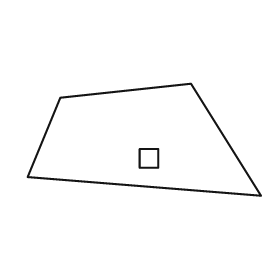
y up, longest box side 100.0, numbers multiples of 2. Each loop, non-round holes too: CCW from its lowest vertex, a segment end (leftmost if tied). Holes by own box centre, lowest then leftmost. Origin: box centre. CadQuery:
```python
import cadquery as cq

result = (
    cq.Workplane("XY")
    .moveTo(50.0, -24.0)
    .lineTo(20.0, 24.0)
    .lineTo(-36.0, 18.0)
    .lineTo(-50.0, -16.0)
    .close()
    .moveTo(-2.0, -12.0)
    .lineTo(6.0, -12.0)
    .lineTo(6.0, -4.0)
    .lineTo(-2.0, -4.0)
    .close()
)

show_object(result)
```